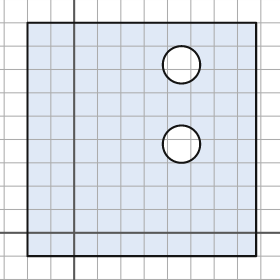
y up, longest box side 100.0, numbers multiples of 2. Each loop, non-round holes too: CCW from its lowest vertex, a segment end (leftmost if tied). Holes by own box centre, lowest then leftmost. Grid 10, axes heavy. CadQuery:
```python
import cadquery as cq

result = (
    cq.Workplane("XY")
    .moveTo(-20.0, -10.0)
    .lineTo(78.0, -10.0)
    .lineTo(78.0, 90.0)
    .lineTo(-20.0, 90.0)
    .close()
    .moveTo(46.0, 38.0)
    .circle(8.0)
    .moveTo(46.0, 72.0)
    .circle(8.0)
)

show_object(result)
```